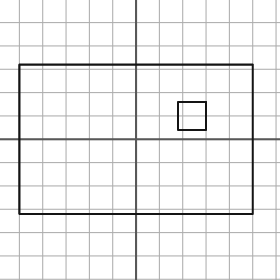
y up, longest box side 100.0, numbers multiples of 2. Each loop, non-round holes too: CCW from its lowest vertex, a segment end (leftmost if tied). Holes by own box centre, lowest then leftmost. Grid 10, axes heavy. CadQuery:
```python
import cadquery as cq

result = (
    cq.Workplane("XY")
    .moveTo(-50.0, -32.0)
    .lineTo(50.0, -32.0)
    .lineTo(50.0, 32.0)
    .lineTo(-50.0, 32.0)
    .close()
    .moveTo(18.0, 4.0)
    .lineTo(30.0, 4.0)
    .lineTo(30.0, 16.0)
    .lineTo(18.0, 16.0)
    .close()
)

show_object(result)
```